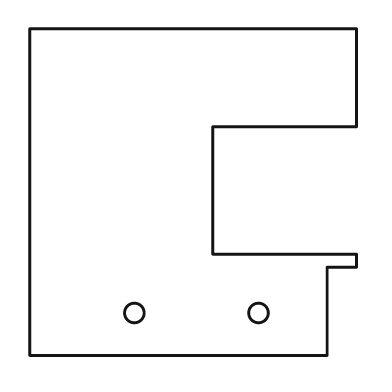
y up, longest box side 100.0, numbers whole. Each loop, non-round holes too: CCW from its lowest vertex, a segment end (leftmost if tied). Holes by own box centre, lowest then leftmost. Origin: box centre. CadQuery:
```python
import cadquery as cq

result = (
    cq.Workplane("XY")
    .moveTo(-50.0, -50.0)
    .lineTo(41.0, -50.0)
    .lineTo(41.0, -23.0)
    .lineTo(50.0, -23.0)
    .lineTo(50.0, -19.0)
    .lineTo(6.0, -19.0)
    .lineTo(6.0, 20.0)
    .lineTo(50.0, 20.0)
    .lineTo(50.0, 50.0)
    .lineTo(-50.0, 50.0)
    .close()
    .moveTo(-18.0, -37.0)
    .circle(3.0)
    .moveTo(20.0, -37.0)
    .circle(3.0)
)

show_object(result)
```